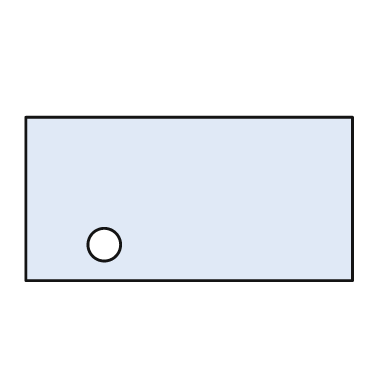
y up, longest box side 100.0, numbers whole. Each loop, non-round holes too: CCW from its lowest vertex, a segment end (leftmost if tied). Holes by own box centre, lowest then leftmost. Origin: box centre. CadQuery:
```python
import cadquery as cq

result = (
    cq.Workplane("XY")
    .moveTo(-50.0, -25.0)
    .lineTo(50.0, -25.0)
    .lineTo(50.0, 25.0)
    .lineTo(-50.0, 25.0)
    .close()
    .moveTo(-26.0, -14.0)
    .circle(5.0)
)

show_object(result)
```